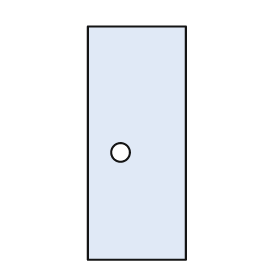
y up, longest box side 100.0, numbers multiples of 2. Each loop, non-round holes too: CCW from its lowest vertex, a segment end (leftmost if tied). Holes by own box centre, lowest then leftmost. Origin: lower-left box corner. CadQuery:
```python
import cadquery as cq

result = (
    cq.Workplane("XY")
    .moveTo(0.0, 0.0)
    .lineTo(42.0, 0.0)
    .lineTo(42.0, 100.0)
    .lineTo(0.0, 100.0)
    .close()
    .moveTo(14.0, 46.0)
    .circle(4.0)
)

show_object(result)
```